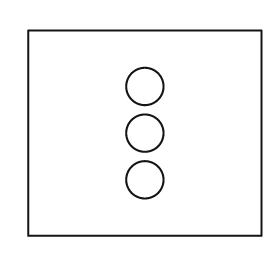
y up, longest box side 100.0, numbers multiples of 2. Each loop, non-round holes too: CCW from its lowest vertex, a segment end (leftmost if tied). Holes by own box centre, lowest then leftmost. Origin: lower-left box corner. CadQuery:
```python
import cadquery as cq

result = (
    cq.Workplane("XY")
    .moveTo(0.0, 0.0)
    .lineTo(100.0, 0.0)
    .lineTo(100.0, 88.0)
    .lineTo(0.0, 88.0)
    .close()
    .moveTo(50.0, 24.0)
    .circle(8.0)
    .moveTo(50.0, 44.0)
    .circle(8.0)
    .moveTo(50.0, 64.0)
    .circle(8.0)
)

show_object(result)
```